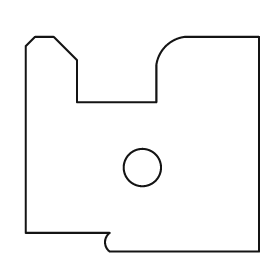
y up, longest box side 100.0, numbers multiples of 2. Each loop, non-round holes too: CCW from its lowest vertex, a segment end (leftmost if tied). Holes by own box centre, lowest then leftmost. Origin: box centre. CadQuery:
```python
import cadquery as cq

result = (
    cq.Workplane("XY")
    .moveTo(-14.0, -46.0)
    .lineTo(50.0, -46.0)
    .lineTo(50.0, 46.0)
    .lineTo(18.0, 46.0)
    .threePointArc((10.0, 42.0), (6.0, 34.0))
    .lineTo(6.0, 18.0)
    .lineTo(-28.0, 18.0)
    .lineTo(-28.0, 36.0)
    .lineTo(-38.0, 46.0)
    .lineTo(-46.0, 46.0)
    .lineTo(-50.0, 42.0)
    .lineTo(-50.0, -38.0)
    .lineTo(-14.0, -38.0)
    .threePointArc((-16.0, -42.0), (-14.0, -46.0))
    .close()
    .moveTo(0.0, -10.0)
    .circle(8.0)
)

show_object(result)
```